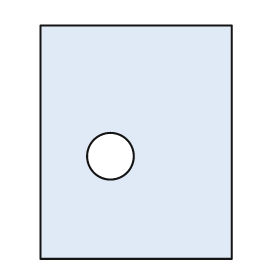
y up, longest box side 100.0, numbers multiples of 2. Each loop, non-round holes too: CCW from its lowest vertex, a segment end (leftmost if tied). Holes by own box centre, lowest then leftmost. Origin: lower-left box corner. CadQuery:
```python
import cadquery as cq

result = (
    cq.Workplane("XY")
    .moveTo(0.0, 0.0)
    .lineTo(82.0, 0.0)
    .lineTo(82.0, 100.0)
    .lineTo(0.0, 100.0)
    .close()
    .moveTo(30.0, 44.0)
    .circle(10.0)
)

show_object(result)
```